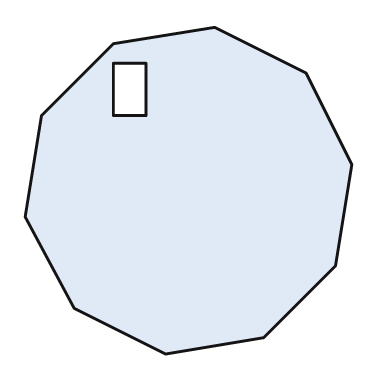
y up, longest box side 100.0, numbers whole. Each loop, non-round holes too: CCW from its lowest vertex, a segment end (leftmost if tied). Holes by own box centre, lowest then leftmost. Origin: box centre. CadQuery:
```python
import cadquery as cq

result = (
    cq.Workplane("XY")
    .moveTo(-7.0, -50.0)
    .lineTo(23.0, -45.0)
    .lineTo(45.0, -23.0)
    .lineTo(50.0, 8.0)
    .lineTo(36.0, 36.0)
    .lineTo(8.0, 50.0)
    .lineTo(-23.0, 45.0)
    .lineTo(-45.0, 23.0)
    .lineTo(-50.0, -8.0)
    .lineTo(-35.0, -36.0)
    .close()
    .moveTo(-23.0, 23.0)
    .lineTo(-13.0, 23.0)
    .lineTo(-13.0, 39.0)
    .lineTo(-23.0, 39.0)
    .close()
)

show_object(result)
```